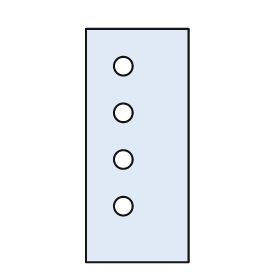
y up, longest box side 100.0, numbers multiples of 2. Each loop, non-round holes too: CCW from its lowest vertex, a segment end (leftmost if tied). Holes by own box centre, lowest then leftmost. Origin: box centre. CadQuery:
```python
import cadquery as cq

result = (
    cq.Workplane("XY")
    .moveTo(-22.0, -50.0)
    .lineTo(22.0, -50.0)
    .lineTo(22.0, 50.0)
    .lineTo(-22.0, 50.0)
    .close()
    .moveTo(-6.0, -26.0)
    .circle(4.0)
    .moveTo(-6.0, -6.0)
    .circle(4.0)
    .moveTo(-6.0, 14.0)
    .circle(4.0)
    .moveTo(-6.0, 34.0)
    .circle(4.0)
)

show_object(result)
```